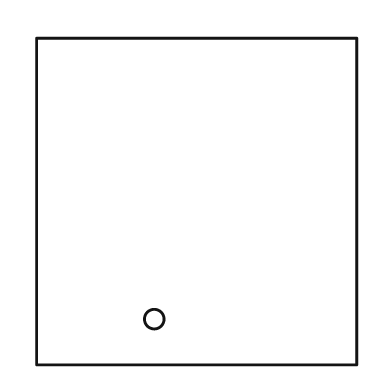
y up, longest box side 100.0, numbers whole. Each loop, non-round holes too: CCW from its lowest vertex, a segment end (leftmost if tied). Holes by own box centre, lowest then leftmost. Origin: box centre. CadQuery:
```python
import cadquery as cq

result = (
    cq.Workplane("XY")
    .moveTo(-49.0, -50.0)
    .lineTo(49.0, -50.0)
    .lineTo(49.0, 50.0)
    .lineTo(-49.0, 50.0)
    .close()
    .moveTo(-13.0, -36.0)
    .circle(3.0)
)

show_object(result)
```